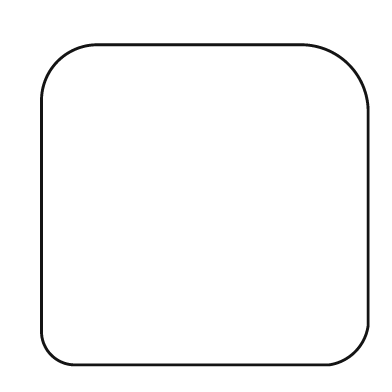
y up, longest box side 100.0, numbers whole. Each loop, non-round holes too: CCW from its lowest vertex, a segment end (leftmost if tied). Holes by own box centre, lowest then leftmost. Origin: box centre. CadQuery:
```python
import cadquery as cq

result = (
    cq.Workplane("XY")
    .moveTo(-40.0, -49.0)
    .lineTo(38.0, -49.0)
    .threePointArc((46.0, -45.0), (50.0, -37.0))
    .lineTo(50.0, 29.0)
    .threePointArc((44.0, 43.0), (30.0, 49.0))
    .lineTo(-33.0, 49.0)
    .threePointArc((-45.0, 44.0), (-50.0, 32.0))
    .lineTo(-50.0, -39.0)
    .threePointArc((-47.0, -46.0), (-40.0, -49.0))
    .close()
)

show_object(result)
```